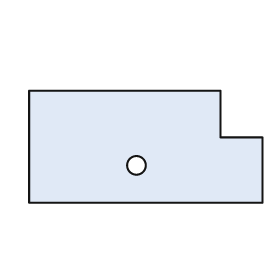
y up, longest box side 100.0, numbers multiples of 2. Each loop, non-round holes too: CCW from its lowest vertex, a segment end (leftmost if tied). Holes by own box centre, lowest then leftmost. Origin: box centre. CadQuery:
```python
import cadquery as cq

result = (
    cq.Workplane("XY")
    .moveTo(-50.0, -24.0)
    .lineTo(50.0, -24.0)
    .lineTo(50.0, 4.0)
    .lineTo(32.0, 4.0)
    .lineTo(32.0, 24.0)
    .lineTo(-50.0, 24.0)
    .close()
    .moveTo(-4.0, -8.0)
    .circle(4.0)
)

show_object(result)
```